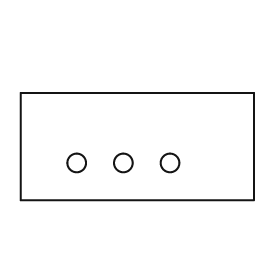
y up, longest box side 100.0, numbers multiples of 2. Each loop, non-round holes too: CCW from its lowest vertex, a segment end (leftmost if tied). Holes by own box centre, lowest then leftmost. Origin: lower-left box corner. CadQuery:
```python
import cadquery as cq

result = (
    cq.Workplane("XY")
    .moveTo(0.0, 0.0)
    .lineTo(100.0, 0.0)
    .lineTo(100.0, 46.0)
    .lineTo(0.0, 46.0)
    .close()
    .moveTo(24.0, 16.0)
    .circle(4.0)
    .moveTo(44.0, 16.0)
    .circle(4.0)
    .moveTo(64.0, 16.0)
    .circle(4.0)
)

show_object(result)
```